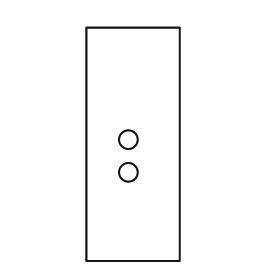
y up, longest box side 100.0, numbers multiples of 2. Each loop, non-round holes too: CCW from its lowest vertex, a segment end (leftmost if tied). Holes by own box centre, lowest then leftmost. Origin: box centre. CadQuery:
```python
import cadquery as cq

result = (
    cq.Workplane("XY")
    .moveTo(-20.0, -50.0)
    .lineTo(20.0, -50.0)
    .lineTo(20.0, 50.0)
    .lineTo(-20.0, 50.0)
    .close()
    .moveTo(-2.0, -12.0)
    .circle(4.0)
    .moveTo(-2.0, 2.0)
    .circle(4.0)
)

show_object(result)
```